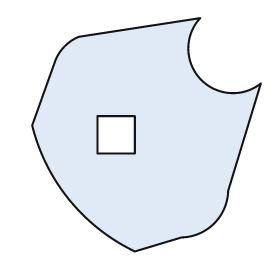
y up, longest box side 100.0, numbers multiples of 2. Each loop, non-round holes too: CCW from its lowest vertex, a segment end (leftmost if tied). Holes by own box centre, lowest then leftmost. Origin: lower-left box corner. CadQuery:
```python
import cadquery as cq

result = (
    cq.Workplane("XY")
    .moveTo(44.0, 0.0)
    .lineTo(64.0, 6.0)
    .threePointArc((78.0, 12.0), (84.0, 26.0))
    .lineTo(98.0, 72.0)
    .threePointArc((72.0, 74.0), (72.0, 100.0))
    .lineTo(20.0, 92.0)
    .threePointArc((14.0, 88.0), (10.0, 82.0))
    .lineTo(0.0, 54.0)
    .threePointArc((16.0, 22.0), (44.0, 0.0))
    .close()
    .moveTo(28.0, 42.0)
    .lineTo(44.0, 42.0)
    .lineTo(44.0, 58.0)
    .lineTo(28.0, 58.0)
    .close()
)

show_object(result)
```